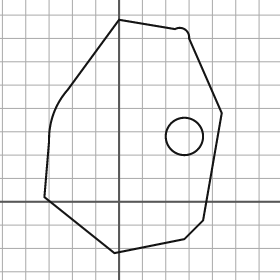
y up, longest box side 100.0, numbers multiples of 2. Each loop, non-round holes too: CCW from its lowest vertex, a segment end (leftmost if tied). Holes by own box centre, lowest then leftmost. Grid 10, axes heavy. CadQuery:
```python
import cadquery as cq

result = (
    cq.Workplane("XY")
    .moveTo(-2.0, -22.0)
    .lineTo(28.0, -16.0)
    .lineTo(36.0, -8.0)
    .lineTo(44.0, 38.0)
    .lineTo(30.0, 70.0)
    .threePointArc((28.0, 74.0), (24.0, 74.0))
    .lineTo(0.0, 78.0)
    .lineTo(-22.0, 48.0)
    .threePointArc((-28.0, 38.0), (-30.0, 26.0))
    .lineTo(-32.0, 2.0)
    .close()
    .moveTo(28.0, 28.0)
    .circle(8.0)
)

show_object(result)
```